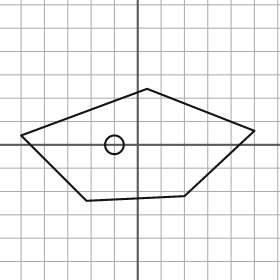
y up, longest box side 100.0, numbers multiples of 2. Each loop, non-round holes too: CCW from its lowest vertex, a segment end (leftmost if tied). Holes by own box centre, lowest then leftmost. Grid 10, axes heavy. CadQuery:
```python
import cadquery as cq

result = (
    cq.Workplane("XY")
    .moveTo(-22.0, -24.0)
    .lineTo(20.0, -22.0)
    .lineTo(50.0, 6.0)
    .lineTo(4.0, 24.0)
    .lineTo(-50.0, 4.0)
    .close()
    .moveTo(-10.0, 0.0)
    .circle(4.0)
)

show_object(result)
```